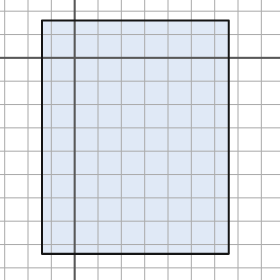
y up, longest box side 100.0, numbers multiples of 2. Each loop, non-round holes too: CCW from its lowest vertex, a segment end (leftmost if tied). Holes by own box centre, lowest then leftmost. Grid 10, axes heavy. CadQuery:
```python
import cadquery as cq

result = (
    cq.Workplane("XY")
    .moveTo(-14.0, -84.0)
    .lineTo(66.0, -84.0)
    .lineTo(66.0, 16.0)
    .lineTo(-14.0, 16.0)
    .close()
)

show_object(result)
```